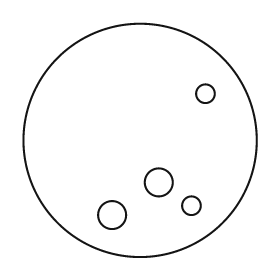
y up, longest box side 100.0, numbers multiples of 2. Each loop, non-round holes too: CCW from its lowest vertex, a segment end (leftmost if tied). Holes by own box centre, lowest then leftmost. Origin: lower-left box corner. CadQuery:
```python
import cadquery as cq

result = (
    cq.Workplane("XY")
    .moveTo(50.0, 50.0)
    .circle(50.0)
    .moveTo(38.0, 18.0)
    .circle(6.0)
    .moveTo(72.0, 22.0)
    .circle(4.0)
    .moveTo(58.0, 32.0)
    .circle(6.0)
    .moveTo(78.0, 70.0)
    .circle(4.0)
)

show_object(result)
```